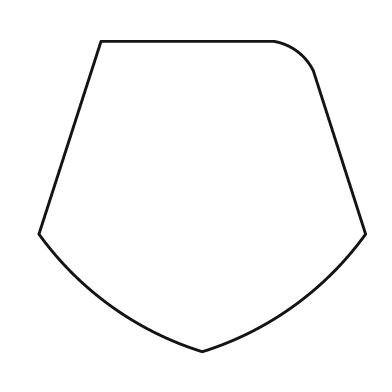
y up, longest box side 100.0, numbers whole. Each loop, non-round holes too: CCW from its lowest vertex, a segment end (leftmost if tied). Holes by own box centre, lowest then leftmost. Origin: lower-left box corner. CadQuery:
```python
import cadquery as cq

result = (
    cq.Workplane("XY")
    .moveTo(50.0, 0.0)
    .threePointArc((78.0, 14.0), (100.0, 36.0))
    .lineTo(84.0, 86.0)
    .threePointArc((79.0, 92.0), (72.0, 95.0))
    .lineTo(19.0, 95.0)
    .lineTo(0.0, 36.0)
    .threePointArc((22.0, 14.0), (50.0, 0.0))
    .close()
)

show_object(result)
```